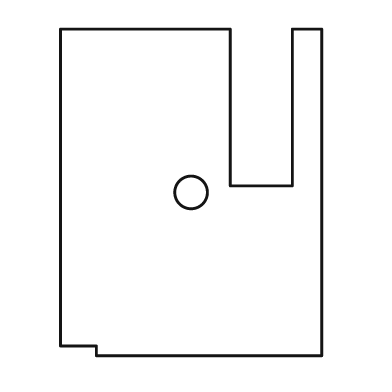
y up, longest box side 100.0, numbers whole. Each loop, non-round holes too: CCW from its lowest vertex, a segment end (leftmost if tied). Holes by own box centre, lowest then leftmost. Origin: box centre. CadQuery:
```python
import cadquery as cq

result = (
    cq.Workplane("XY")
    .moveTo(-29.0, -50.0)
    .lineTo(40.0, -50.0)
    .lineTo(40.0, 50.0)
    .lineTo(31.0, 50.0)
    .lineTo(31.0, 2.0)
    .lineTo(12.0, 2.0)
    .lineTo(12.0, 50.0)
    .lineTo(-40.0, 50.0)
    .lineTo(-40.0, -47.0)
    .lineTo(-29.0, -47.0)
    .close()
    .moveTo(0.0, 0.0)
    .circle(5.0)
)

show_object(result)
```